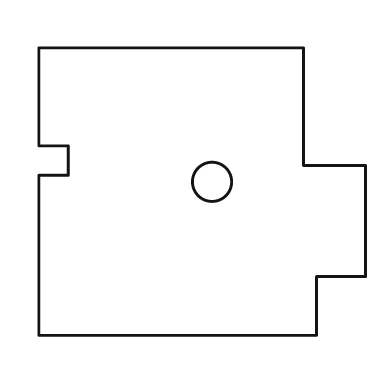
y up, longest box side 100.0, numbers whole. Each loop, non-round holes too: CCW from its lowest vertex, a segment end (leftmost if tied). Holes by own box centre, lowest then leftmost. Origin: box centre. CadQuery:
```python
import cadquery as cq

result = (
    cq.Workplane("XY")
    .moveTo(-50.0, -44.0)
    .lineTo(35.0, -44.0)
    .lineTo(35.0, -26.0)
    .lineTo(50.0, -26.0)
    .lineTo(50.0, 8.0)
    .lineTo(31.0, 8.0)
    .lineTo(31.0, 44.0)
    .lineTo(-50.0, 44.0)
    .lineTo(-50.0, 14.0)
    .lineTo(-41.0, 14.0)
    .lineTo(-41.0, 5.0)
    .lineTo(-50.0, 5.0)
    .close()
    .moveTo(3.0, 3.0)
    .circle(6.0)
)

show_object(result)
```